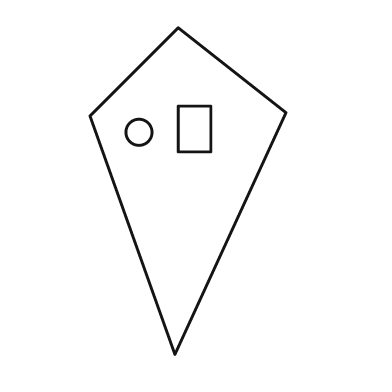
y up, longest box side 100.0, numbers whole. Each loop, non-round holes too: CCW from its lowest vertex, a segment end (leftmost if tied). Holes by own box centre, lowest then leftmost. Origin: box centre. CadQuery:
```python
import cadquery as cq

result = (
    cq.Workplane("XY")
    .moveTo(-4.0, -50.0)
    .lineTo(30.0, 24.0)
    .lineTo(-3.0, 50.0)
    .lineTo(-30.0, 23.0)
    .close()
    .moveTo(-15.0, 18.0)
    .circle(4.0)
    .moveTo(-3.0, 12.0)
    .lineTo(7.0, 12.0)
    .lineTo(7.0, 26.0)
    .lineTo(-3.0, 26.0)
    .close()
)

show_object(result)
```